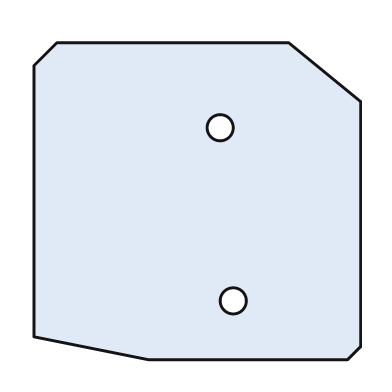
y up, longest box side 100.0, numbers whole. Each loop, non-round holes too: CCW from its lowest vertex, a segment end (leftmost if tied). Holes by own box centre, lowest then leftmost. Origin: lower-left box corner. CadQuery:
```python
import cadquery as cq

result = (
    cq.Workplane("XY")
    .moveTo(35.0, 0.0)
    .lineTo(96.0, 0.0)
    .lineTo(100.0, 4.0)
    .lineTo(100.0, 79.0)
    .lineTo(78.0, 97.0)
    .lineTo(7.0, 97.0)
    .lineTo(0.0, 90.0)
    .lineTo(0.0, 7.0)
    .close()
    .moveTo(61.0, 18.0)
    .circle(4.0)
    .moveTo(57.0, 71.0)
    .circle(4.0)
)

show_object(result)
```